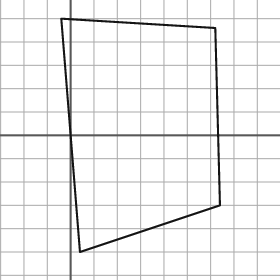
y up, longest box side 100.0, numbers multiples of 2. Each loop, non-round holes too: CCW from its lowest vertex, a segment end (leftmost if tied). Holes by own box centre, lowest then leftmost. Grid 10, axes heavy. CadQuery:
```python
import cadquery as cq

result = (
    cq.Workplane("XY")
    .moveTo(4.0, -50.0)
    .lineTo(64.0, -30.0)
    .lineTo(62.0, 46.0)
    .lineTo(-4.0, 50.0)
    .close()
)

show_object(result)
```